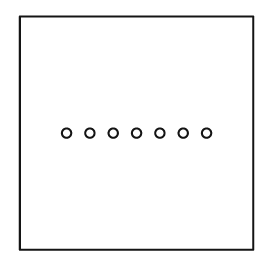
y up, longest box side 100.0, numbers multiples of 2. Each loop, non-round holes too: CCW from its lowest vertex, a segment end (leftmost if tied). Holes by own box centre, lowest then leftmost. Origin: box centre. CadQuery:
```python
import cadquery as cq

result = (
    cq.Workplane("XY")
    .moveTo(-50.0, -50.0)
    .lineTo(50.0, -50.0)
    .lineTo(50.0, 50.0)
    .lineTo(-50.0, 50.0)
    .close()
    .moveTo(-30.0, 0.0)
    .circle(2.0)
    .moveTo(-20.0, 0.0)
    .circle(2.0)
    .moveTo(-10.0, 0.0)
    .circle(2.0)
    .moveTo(0.0, 0.0)
    .circle(2.0)
    .moveTo(10.0, 0.0)
    .circle(2.0)
    .moveTo(20.0, 0.0)
    .circle(2.0)
    .moveTo(30.0, 0.0)
    .circle(2.0)
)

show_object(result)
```